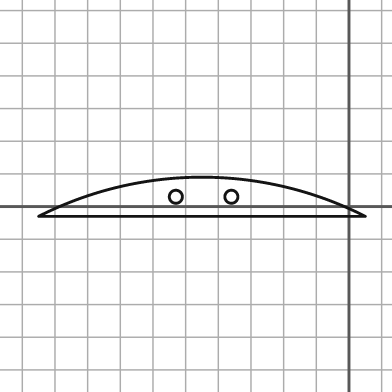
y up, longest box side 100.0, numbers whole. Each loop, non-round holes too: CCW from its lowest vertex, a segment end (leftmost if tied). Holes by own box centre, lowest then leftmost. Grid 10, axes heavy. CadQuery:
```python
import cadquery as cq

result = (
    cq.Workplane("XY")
    .moveTo(-95.0, -3.0)
    .lineTo(5.0, -3.0)
    .threePointArc((-45.0, 9.0), (-95.0, -3.0))
    .close()
    .moveTo(-53.0, 3.0)
    .circle(2.0)
    .moveTo(-36.0, 3.0)
    .circle(2.0)
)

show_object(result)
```